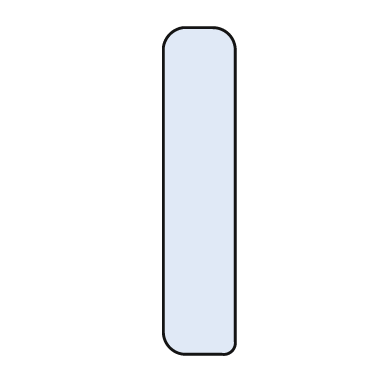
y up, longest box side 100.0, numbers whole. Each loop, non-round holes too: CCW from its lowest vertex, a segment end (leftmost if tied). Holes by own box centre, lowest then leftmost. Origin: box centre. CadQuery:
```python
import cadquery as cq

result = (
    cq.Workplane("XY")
    .moveTo(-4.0, -50.0)
    .lineTo(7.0, -50.0)
    .threePointArc((10.0, -49.0), (11.0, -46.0))
    .lineTo(11.0, 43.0)
    .threePointArc((9.0, 48.0), (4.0, 50.0))
    .lineTo(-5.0, 50.0)
    .threePointArc((-9.0, 48.0), (-11.0, 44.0))
    .lineTo(-11.0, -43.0)
    .threePointArc((-9.0, -48.0), (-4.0, -50.0))
    .close()
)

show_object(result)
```